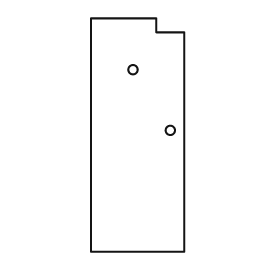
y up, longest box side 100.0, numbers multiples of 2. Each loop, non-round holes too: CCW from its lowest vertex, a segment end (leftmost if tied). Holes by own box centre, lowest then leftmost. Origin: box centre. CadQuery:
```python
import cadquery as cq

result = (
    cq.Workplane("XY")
    .moveTo(-20.0, -50.0)
    .lineTo(20.0, -50.0)
    .lineTo(20.0, 44.0)
    .lineTo(8.0, 44.0)
    .lineTo(8.0, 50.0)
    .lineTo(-20.0, 50.0)
    .close()
    .moveTo(14.0, 2.0)
    .circle(2.0)
    .moveTo(-2.0, 28.0)
    .circle(2.0)
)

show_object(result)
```